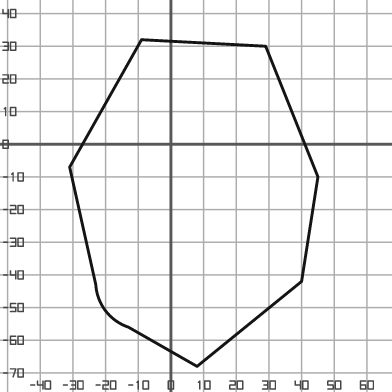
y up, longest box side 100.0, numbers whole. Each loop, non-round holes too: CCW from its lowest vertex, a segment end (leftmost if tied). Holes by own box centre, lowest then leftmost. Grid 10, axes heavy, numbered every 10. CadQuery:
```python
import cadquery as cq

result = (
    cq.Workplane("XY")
    .moveTo(8.0, -68.0)
    .lineTo(40.0, -42.0)
    .lineTo(45.0, -10.0)
    .lineTo(29.0, 30.0)
    .lineTo(-9.0, 32.0)
    .lineTo(-31.0, -7.0)
    .lineTo(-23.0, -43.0)
    .threePointArc((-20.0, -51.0), (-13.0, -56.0))
    .close()
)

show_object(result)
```